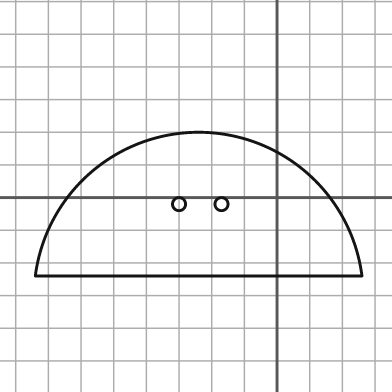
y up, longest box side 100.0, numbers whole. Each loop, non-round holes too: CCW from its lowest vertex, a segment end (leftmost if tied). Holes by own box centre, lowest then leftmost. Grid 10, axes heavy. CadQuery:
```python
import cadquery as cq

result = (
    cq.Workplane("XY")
    .moveTo(-74.0, -24.0)
    .lineTo(26.0, -24.0)
    .threePointArc((-24.0, 20.0), (-74.0, -24.0))
    .close()
    .moveTo(-30.0, -2.0)
    .circle(2.0)
    .moveTo(-17.0, -2.0)
    .circle(2.0)
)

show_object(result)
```